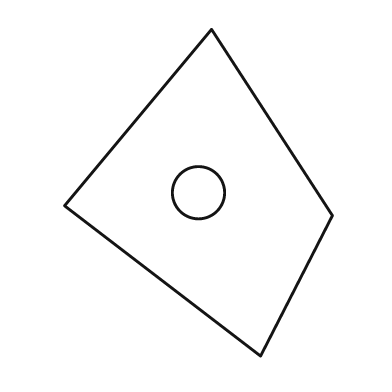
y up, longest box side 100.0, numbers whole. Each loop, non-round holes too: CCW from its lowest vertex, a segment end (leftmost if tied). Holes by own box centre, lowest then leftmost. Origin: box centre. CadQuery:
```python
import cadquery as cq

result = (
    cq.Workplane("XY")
    .moveTo(19.0, -50.0)
    .lineTo(41.0, -7.0)
    .lineTo(4.0, 50.0)
    .lineTo(-41.0, -4.0)
    .close()
    .moveTo(0.0, 0.0)
    .circle(8.0)
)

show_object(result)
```